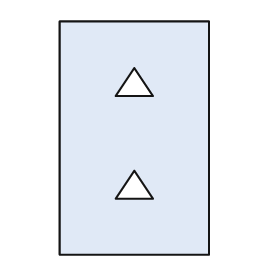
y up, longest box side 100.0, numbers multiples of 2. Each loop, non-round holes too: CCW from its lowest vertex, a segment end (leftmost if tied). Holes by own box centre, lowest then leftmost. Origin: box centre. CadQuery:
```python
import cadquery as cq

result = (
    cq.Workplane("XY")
    .moveTo(-32.0, -50.0)
    .lineTo(32.0, -50.0)
    .lineTo(32.0, 50.0)
    .lineTo(-32.0, 50.0)
    .close()
    .moveTo(-8.0, -26.0)
    .lineTo(8.0, -26.0)
    .lineTo(0.0, -14.0)
    .close()
    .moveTo(-8.0, 18.0)
    .lineTo(8.0, 18.0)
    .lineTo(0.0, 30.0)
    .close()
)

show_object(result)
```